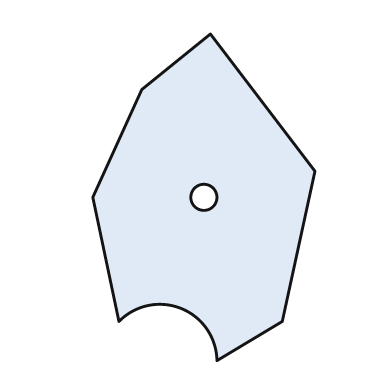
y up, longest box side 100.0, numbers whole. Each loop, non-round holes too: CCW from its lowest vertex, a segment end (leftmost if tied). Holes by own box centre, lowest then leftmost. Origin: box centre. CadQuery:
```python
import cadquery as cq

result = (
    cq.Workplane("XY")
    .moveTo(4.0, -50.0)
    .lineTo(24.0, -38.0)
    .lineTo(34.0, 8.0)
    .lineTo(2.0, 50.0)
    .lineTo(-19.0, 33.0)
    .lineTo(-34.0, 0.0)
    .lineTo(-26.0, -38.0)
    .threePointArc((-7.0, -34.0), (4.0, -50.0))
    .close()
    .moveTo(0.0, 0.0)
    .circle(4.0)
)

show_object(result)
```